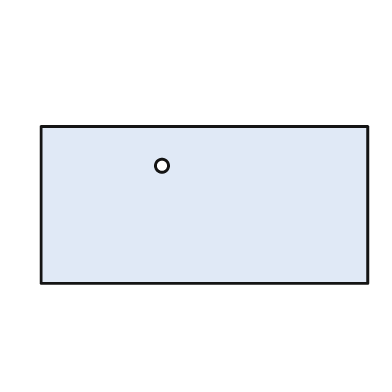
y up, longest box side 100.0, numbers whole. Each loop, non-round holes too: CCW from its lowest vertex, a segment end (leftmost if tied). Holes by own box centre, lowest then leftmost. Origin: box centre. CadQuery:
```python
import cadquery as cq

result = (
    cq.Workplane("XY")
    .moveTo(-50.0, -24.0)
    .lineTo(50.0, -24.0)
    .lineTo(50.0, 24.0)
    .lineTo(-50.0, 24.0)
    .close()
    .moveTo(-13.0, 12.0)
    .circle(2.0)
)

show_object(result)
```